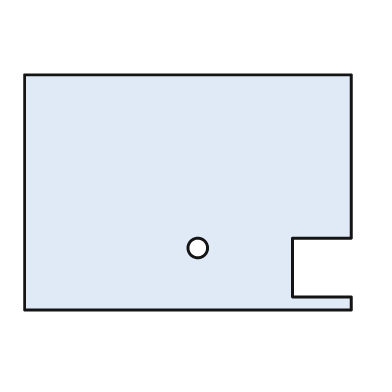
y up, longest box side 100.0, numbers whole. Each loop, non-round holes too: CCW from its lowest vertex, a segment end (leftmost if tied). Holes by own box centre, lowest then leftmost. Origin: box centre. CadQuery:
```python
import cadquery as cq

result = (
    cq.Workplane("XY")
    .moveTo(-50.0, -36.0)
    .lineTo(50.0, -36.0)
    .lineTo(50.0, -32.0)
    .lineTo(32.0, -32.0)
    .lineTo(32.0, -14.0)
    .lineTo(50.0, -14.0)
    .lineTo(50.0, 36.0)
    .lineTo(-50.0, 36.0)
    .close()
    .moveTo(3.0, -17.0)
    .circle(3.0)
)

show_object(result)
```